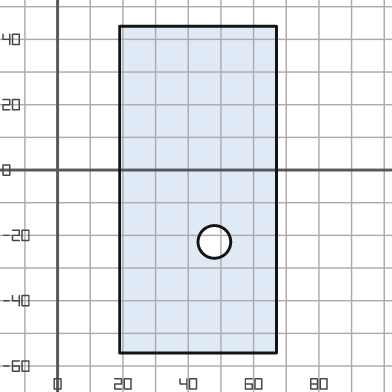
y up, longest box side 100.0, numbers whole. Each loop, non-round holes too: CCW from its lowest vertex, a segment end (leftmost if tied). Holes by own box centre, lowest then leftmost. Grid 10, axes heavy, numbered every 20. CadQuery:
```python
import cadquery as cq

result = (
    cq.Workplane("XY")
    .moveTo(19.0, -56.0)
    .lineTo(67.0, -56.0)
    .lineTo(67.0, 44.0)
    .lineTo(19.0, 44.0)
    .close()
    .moveTo(48.0, -22.0)
    .circle(5.0)
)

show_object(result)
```